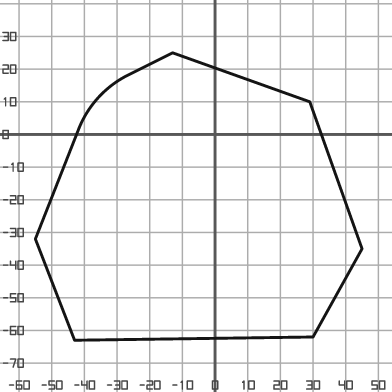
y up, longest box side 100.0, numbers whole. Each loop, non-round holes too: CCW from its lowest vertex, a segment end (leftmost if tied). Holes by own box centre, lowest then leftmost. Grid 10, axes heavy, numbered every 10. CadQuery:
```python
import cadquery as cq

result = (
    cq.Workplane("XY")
    .moveTo(-43.0, -63.0)
    .lineTo(30.0, -62.0)
    .lineTo(45.0, -35.0)
    .lineTo(29.0, 10.0)
    .lineTo(-13.0, 25.0)
    .lineTo(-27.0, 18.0)
    .threePointArc((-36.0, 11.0), (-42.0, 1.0))
    .lineTo(-55.0, -32.0)
    .close()
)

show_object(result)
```